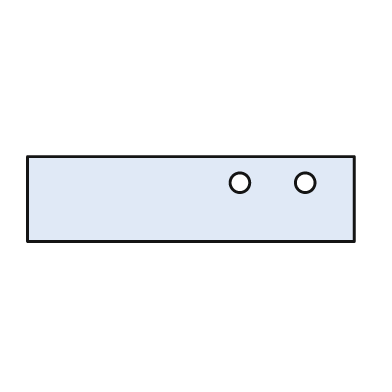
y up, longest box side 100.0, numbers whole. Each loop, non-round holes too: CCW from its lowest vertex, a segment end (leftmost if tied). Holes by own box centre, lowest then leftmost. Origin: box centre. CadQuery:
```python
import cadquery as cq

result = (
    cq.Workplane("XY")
    .moveTo(-50.0, -13.0)
    .lineTo(50.0, -13.0)
    .lineTo(50.0, 13.0)
    .lineTo(-50.0, 13.0)
    .close()
    .moveTo(15.0, 5.0)
    .circle(3.0)
    .moveTo(35.0, 5.0)
    .circle(3.0)
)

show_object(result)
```